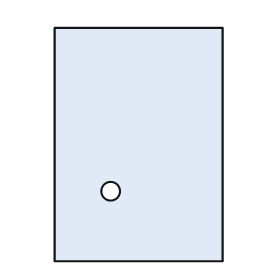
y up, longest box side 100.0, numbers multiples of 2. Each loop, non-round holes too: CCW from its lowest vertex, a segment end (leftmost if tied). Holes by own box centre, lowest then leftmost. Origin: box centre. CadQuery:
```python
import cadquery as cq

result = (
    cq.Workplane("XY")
    .moveTo(-36.0, -50.0)
    .lineTo(36.0, -50.0)
    .lineTo(36.0, 50.0)
    .lineTo(-36.0, 50.0)
    .close()
    .moveTo(-12.0, -20.0)
    .circle(4.0)
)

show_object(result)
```